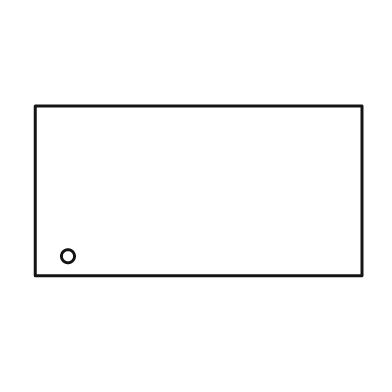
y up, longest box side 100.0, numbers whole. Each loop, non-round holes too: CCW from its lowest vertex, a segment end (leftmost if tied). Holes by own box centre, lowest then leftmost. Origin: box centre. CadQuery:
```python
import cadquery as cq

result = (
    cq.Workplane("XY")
    .moveTo(-50.0, -26.0)
    .lineTo(50.0, -26.0)
    .lineTo(50.0, 26.0)
    .lineTo(-50.0, 26.0)
    .close()
    .moveTo(-40.0, -20.0)
    .circle(2.0)
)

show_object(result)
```